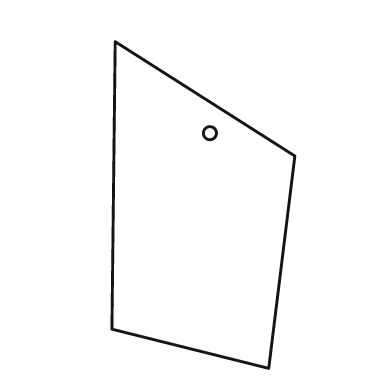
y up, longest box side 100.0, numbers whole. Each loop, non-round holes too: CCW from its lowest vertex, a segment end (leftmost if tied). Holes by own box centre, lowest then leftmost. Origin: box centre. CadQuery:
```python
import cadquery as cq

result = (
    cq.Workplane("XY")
    .moveTo(20.0, -50.0)
    .lineTo(28.0, 15.0)
    .lineTo(-27.0, 50.0)
    .lineTo(-28.0, -38.0)
    .close()
    .moveTo(2.0, 22.0)
    .circle(2.0)
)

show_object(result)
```